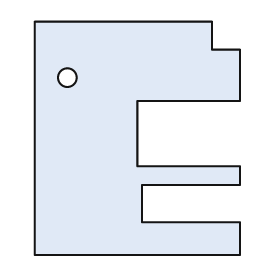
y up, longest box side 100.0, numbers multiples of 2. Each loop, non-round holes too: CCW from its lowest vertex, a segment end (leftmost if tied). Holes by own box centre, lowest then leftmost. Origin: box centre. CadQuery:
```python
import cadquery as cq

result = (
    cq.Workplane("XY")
    .moveTo(-44.0, -50.0)
    .lineTo(44.0, -50.0)
    .lineTo(44.0, -36.0)
    .lineTo(2.0, -36.0)
    .lineTo(2.0, -20.0)
    .lineTo(44.0, -20.0)
    .lineTo(44.0, -12.0)
    .lineTo(0.0, -12.0)
    .lineTo(0.0, 16.0)
    .lineTo(44.0, 16.0)
    .lineTo(44.0, 38.0)
    .lineTo(32.0, 38.0)
    .lineTo(32.0, 50.0)
    .lineTo(-44.0, 50.0)
    .close()
    .moveTo(-30.0, 26.0)
    .circle(4.0)
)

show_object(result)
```